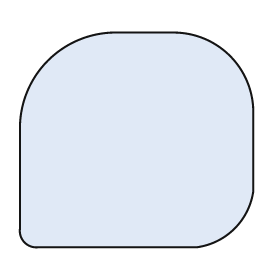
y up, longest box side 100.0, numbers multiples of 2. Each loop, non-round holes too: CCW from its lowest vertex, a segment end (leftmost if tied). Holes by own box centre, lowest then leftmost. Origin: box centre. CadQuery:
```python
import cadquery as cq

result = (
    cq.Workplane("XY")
    .moveTo(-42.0, -46.0)
    .lineTo(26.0, -46.0)
    .threePointArc((42.0, -38.0), (50.0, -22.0))
    .lineTo(50.0, 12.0)
    .threePointArc((40.0, 36.0), (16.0, 46.0))
    .lineTo(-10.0, 46.0)
    .threePointArc((-38.0, 34.0), (-50.0, 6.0))
    .lineTo(-50.0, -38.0)
    .threePointArc((-48.0, -44.0), (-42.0, -46.0))
    .close()
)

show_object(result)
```